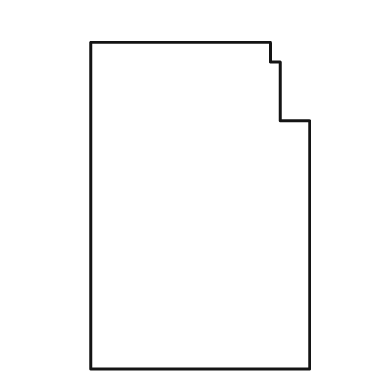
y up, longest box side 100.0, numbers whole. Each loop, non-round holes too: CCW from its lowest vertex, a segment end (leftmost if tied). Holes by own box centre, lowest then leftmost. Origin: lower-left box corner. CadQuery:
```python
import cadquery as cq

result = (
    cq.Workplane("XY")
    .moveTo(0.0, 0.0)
    .lineTo(67.0, 0.0)
    .lineTo(67.0, 76.0)
    .lineTo(58.0, 76.0)
    .lineTo(58.0, 94.0)
    .lineTo(55.0, 94.0)
    .lineTo(55.0, 100.0)
    .lineTo(0.0, 100.0)
    .close()
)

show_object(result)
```